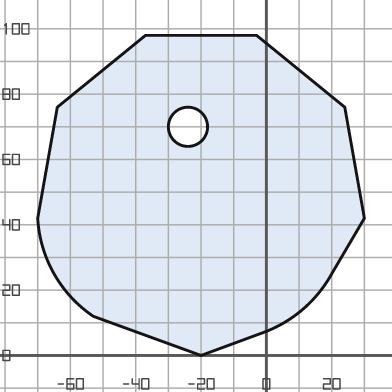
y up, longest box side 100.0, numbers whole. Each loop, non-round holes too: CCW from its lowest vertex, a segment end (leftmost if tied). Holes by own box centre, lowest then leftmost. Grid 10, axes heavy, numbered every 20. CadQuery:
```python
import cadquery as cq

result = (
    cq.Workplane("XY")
    .moveTo(-20.0, 0.0)
    .lineTo(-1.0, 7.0)
    .threePointArc((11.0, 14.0), (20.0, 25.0))
    .lineTo(30.0, 42.0)
    .lineTo(24.0, 76.0)
    .lineTo(-3.0, 98.0)
    .lineTo(-37.0, 98.0)
    .lineTo(-64.0, 76.0)
    .lineTo(-70.0, 42.0)
    .threePointArc((-65.0, 25.0), (-53.0, 12.0))
    .close()
    .moveTo(-24.0, 70.0)
    .circle(6.0)
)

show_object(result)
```